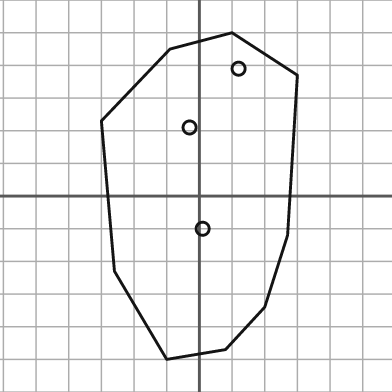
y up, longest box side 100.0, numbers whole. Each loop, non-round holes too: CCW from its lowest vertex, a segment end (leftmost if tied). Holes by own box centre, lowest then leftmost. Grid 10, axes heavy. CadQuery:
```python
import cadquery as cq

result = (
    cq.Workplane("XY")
    .moveTo(-10.0, -50.0)
    .lineTo(8.0, -47.0)
    .lineTo(20.0, -34.0)
    .lineTo(27.0, -12.0)
    .lineTo(30.0, 37.0)
    .lineTo(10.0, 50.0)
    .lineTo(-9.0, 45.0)
    .lineTo(-30.0, 23.0)
    .lineTo(-26.0, -23.0)
    .close()
    .moveTo(1.0, -10.0)
    .circle(2.0)
    .moveTo(-3.0, 21.0)
    .circle(2.0)
    .moveTo(12.0, 39.0)
    .circle(2.0)
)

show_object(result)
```